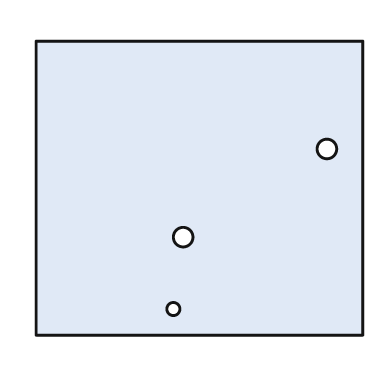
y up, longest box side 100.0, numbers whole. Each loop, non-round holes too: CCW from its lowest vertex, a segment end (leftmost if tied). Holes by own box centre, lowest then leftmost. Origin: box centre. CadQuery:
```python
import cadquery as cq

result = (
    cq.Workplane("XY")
    .moveTo(-50.0, -45.0)
    .lineTo(50.0, -45.0)
    .lineTo(50.0, 45.0)
    .lineTo(-50.0, 45.0)
    .close()
    .moveTo(-8.0, -37.0)
    .circle(2.0)
    .moveTo(-5.0, -15.0)
    .circle(3.0)
    .moveTo(39.0, 12.0)
    .circle(3.0)
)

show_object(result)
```